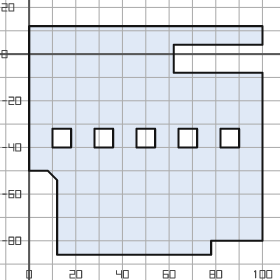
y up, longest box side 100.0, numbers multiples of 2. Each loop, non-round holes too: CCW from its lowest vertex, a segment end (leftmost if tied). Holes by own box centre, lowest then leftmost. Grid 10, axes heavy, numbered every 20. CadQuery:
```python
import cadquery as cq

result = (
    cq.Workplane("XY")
    .moveTo(12.0, -86.0)
    .lineTo(78.0, -86.0)
    .lineTo(78.0, -80.0)
    .lineTo(100.0, -80.0)
    .lineTo(100.0, -8.0)
    .lineTo(62.0, -8.0)
    .lineTo(62.0, 4.0)
    .lineTo(100.0, 4.0)
    .lineTo(100.0, 12.0)
    .lineTo(0.0, 12.0)
    .lineTo(0.0, -50.0)
    .lineTo(8.0, -50.0)
    .lineTo(12.0, -54.0)
    .close()
    .moveTo(10.0, -40.0)
    .lineTo(18.0, -40.0)
    .lineTo(18.0, -32.0)
    .lineTo(10.0, -32.0)
    .close()
    .moveTo(28.0, -40.0)
    .lineTo(36.0, -40.0)
    .lineTo(36.0, -32.0)
    .lineTo(28.0, -32.0)
    .close()
    .moveTo(46.0, -40.0)
    .lineTo(54.0, -40.0)
    .lineTo(54.0, -32.0)
    .lineTo(46.0, -32.0)
    .close()
    .moveTo(64.0, -40.0)
    .lineTo(72.0, -40.0)
    .lineTo(72.0, -32.0)
    .lineTo(64.0, -32.0)
    .close()
    .moveTo(82.0, -40.0)
    .lineTo(90.0, -40.0)
    .lineTo(90.0, -32.0)
    .lineTo(82.0, -32.0)
    .close()
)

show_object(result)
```